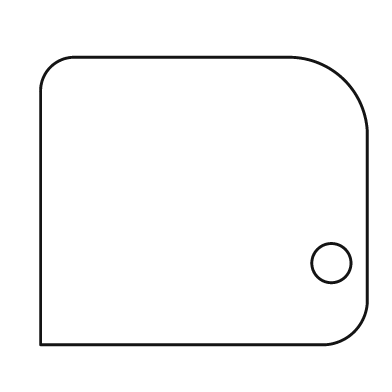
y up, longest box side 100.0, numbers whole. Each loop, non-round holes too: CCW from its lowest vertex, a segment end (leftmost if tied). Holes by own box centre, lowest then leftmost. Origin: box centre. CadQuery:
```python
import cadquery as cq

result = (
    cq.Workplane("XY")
    .moveTo(-50.0, -44.0)
    .lineTo(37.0, -44.0)
    .threePointArc((46.0, -40.0), (50.0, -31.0))
    .lineTo(50.0, 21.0)
    .threePointArc((43.0, 37.0), (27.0, 44.0))
    .lineTo(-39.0, 44.0)
    .threePointArc((-47.0, 41.0), (-50.0, 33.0))
    .close()
    .moveTo(39.0, -19.0)
    .circle(6.0)
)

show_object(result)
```